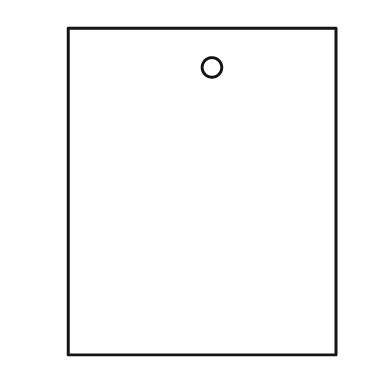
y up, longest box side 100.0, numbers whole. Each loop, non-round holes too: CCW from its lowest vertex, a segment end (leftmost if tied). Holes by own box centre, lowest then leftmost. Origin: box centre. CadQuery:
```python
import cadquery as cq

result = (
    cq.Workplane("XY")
    .moveTo(-41.0, -50.0)
    .lineTo(41.0, -50.0)
    .lineTo(41.0, 50.0)
    .lineTo(-41.0, 50.0)
    .close()
    .moveTo(3.0, 38.0)
    .circle(3.0)
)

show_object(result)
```